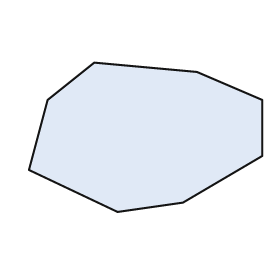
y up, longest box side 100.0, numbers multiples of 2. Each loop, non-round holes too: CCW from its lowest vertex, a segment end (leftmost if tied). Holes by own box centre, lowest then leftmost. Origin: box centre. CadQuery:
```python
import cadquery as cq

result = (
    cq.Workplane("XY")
    .moveTo(-12.0, -32.0)
    .lineTo(16.0, -28.0)
    .lineTo(50.0, -8.0)
    .lineTo(50.0, 16.0)
    .lineTo(22.0, 28.0)
    .lineTo(-22.0, 32.0)
    .lineTo(-42.0, 16.0)
    .lineTo(-50.0, -14.0)
    .close()
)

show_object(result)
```